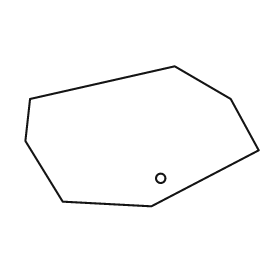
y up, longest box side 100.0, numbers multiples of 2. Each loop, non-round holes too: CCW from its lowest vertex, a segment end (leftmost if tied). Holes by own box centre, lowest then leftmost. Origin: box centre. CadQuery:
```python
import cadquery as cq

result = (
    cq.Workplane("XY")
    .moveTo(4.0, -30.0)
    .lineTo(50.0, -6.0)
    .lineTo(38.0, 16.0)
    .lineTo(14.0, 30.0)
    .lineTo(-48.0, 16.0)
    .lineTo(-50.0, -2.0)
    .lineTo(-34.0, -28.0)
    .close()
    .moveTo(8.0, -18.0)
    .circle(2.0)
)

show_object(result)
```